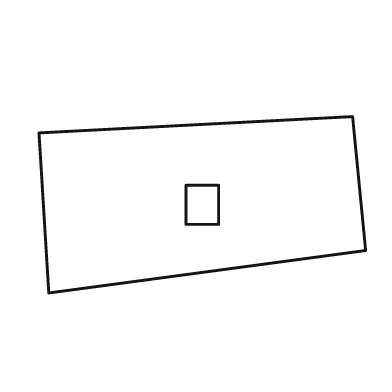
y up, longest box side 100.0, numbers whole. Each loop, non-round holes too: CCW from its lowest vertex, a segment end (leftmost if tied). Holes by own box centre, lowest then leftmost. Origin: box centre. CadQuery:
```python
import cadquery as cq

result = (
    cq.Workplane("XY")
    .moveTo(-47.0, -27.0)
    .lineTo(50.0, -14.0)
    .lineTo(46.0, 27.0)
    .lineTo(-50.0, 22.0)
    .close()
    .moveTo(-5.0, -6.0)
    .lineTo(5.0, -6.0)
    .lineTo(5.0, 6.0)
    .lineTo(-5.0, 6.0)
    .close()
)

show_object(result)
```